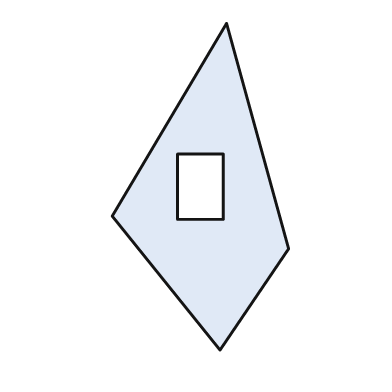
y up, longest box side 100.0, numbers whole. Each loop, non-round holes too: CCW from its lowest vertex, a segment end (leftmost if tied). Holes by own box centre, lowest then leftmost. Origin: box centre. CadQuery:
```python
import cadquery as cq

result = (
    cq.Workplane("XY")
    .moveTo(6.0, -50.0)
    .lineTo(27.0, -19.0)
    .lineTo(8.0, 50.0)
    .lineTo(-27.0, -9.0)
    .close()
    .moveTo(-7.0, -10.0)
    .lineTo(7.0, -10.0)
    .lineTo(7.0, 10.0)
    .lineTo(-7.0, 10.0)
    .close()
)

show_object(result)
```